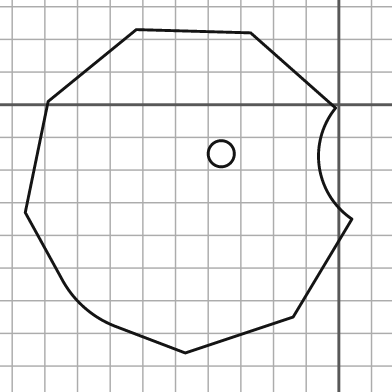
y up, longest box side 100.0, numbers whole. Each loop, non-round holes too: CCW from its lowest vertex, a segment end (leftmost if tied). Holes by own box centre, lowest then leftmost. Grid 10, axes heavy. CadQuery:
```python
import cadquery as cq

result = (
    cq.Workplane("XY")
    .moveTo(-47.0, -76.0)
    .lineTo(-14.0, -65.0)
    .lineTo(4.0, -35.0)
    .threePointArc((-6.0, -19.0), (-1.0, -1.0))
    .lineTo(-27.0, 22.0)
    .lineTo(-62.0, 23.0)
    .lineTo(-89.0, 1.0)
    .lineTo(-96.0, -33.0)
    .lineTo(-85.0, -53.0)
    .threePointArc((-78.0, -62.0), (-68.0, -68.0))
    .close()
    .moveTo(-36.0, -15.0)
    .circle(4.0)
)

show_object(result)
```